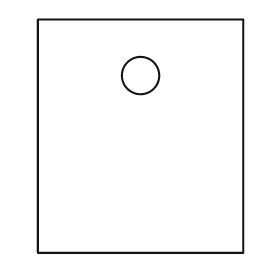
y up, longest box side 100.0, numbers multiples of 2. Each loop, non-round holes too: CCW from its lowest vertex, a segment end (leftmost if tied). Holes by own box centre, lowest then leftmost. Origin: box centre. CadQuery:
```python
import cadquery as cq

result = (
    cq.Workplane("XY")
    .moveTo(-44.0, -50.0)
    .lineTo(44.0, -50.0)
    .lineTo(44.0, 50.0)
    .lineTo(-44.0, 50.0)
    .close()
    .moveTo(0.0, 26.0)
    .circle(8.0)
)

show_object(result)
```